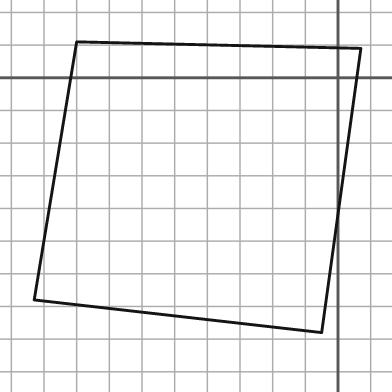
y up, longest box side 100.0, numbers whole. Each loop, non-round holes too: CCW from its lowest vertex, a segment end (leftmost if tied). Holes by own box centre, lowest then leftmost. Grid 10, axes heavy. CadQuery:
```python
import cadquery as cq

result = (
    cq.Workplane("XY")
    .moveTo(-5.0, -78.0)
    .lineTo(7.0, 9.0)
    .lineTo(-80.0, 11.0)
    .lineTo(-93.0, -68.0)
    .close()
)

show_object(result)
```